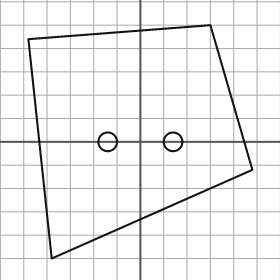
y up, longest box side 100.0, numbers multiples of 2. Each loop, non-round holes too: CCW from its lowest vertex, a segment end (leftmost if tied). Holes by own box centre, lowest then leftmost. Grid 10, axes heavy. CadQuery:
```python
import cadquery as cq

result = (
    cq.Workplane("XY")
    .moveTo(-38.0, -50.0)
    .lineTo(48.0, -12.0)
    .lineTo(30.0, 50.0)
    .lineTo(-48.0, 44.0)
    .close()
    .moveTo(-14.0, 0.0)
    .circle(4.0)
    .moveTo(14.0, 0.0)
    .circle(4.0)
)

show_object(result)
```